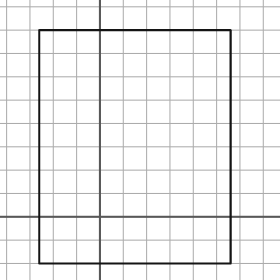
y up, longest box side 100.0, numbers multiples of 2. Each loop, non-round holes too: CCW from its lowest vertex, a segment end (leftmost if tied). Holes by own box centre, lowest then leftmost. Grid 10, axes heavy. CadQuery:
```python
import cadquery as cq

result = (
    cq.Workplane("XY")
    .moveTo(-26.0, -20.0)
    .lineTo(56.0, -20.0)
    .lineTo(56.0, 80.0)
    .lineTo(-26.0, 80.0)
    .close()
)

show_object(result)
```